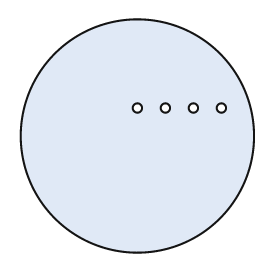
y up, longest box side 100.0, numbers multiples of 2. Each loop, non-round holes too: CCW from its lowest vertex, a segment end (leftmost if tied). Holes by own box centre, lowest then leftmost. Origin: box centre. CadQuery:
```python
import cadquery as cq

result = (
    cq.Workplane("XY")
    .moveTo(0.0, 0.0)
    .circle(50.0)
    .moveTo(0.0, 12.0)
    .circle(2.0)
    .moveTo(12.0, 12.0)
    .circle(2.0)
    .moveTo(24.0, 12.0)
    .circle(2.0)
    .moveTo(36.0, 12.0)
    .circle(2.0)
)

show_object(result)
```